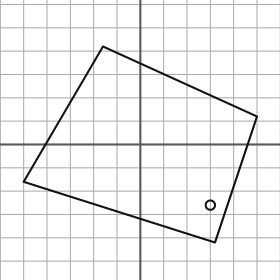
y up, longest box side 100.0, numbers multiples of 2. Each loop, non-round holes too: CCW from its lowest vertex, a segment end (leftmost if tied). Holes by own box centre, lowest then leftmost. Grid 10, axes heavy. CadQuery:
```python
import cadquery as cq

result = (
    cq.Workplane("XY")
    .moveTo(32.0, -42.0)
    .lineTo(50.0, 12.0)
    .lineTo(-16.0, 42.0)
    .lineTo(-50.0, -16.0)
    .close()
    .moveTo(30.0, -26.0)
    .circle(2.0)
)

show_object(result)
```